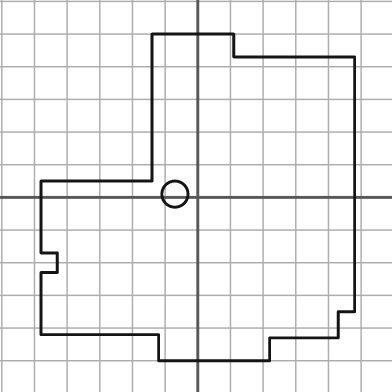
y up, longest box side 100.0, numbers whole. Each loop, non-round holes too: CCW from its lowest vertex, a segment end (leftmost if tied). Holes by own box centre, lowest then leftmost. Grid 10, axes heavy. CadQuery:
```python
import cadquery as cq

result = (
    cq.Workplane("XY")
    .moveTo(-12.0, -50.0)
    .lineTo(22.0, -50.0)
    .lineTo(22.0, -43.0)
    .lineTo(43.0, -43.0)
    .lineTo(43.0, -35.0)
    .lineTo(48.0, -35.0)
    .lineTo(48.0, 43.0)
    .lineTo(11.0, 43.0)
    .lineTo(11.0, 50.0)
    .lineTo(-14.0, 50.0)
    .lineTo(-14.0, 5.0)
    .lineTo(-48.0, 5.0)
    .lineTo(-48.0, -17.0)
    .lineTo(-43.0, -17.0)
    .lineTo(-43.0, -23.0)
    .lineTo(-48.0, -23.0)
    .lineTo(-48.0, -42.0)
    .lineTo(-12.0, -42.0)
    .close()
    .moveTo(-7.0, 1.0)
    .circle(4.0)
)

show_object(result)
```